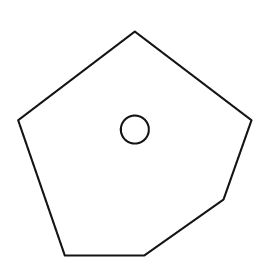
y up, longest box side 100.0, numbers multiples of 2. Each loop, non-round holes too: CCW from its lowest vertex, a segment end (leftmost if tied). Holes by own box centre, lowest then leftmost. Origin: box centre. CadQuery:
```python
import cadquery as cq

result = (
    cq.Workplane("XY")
    .moveTo(-30.0, -48.0)
    .lineTo(4.0, -48.0)
    .lineTo(38.0, -24.0)
    .lineTo(50.0, 10.0)
    .lineTo(0.0, 48.0)
    .lineTo(-50.0, 10.0)
    .close()
    .moveTo(0.0, 6.0)
    .circle(6.0)
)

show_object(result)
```